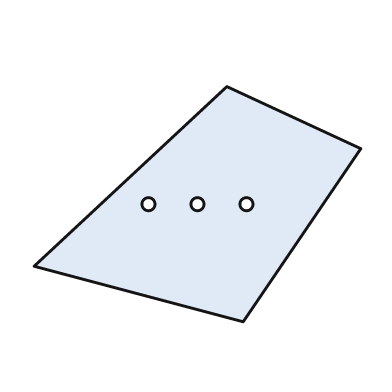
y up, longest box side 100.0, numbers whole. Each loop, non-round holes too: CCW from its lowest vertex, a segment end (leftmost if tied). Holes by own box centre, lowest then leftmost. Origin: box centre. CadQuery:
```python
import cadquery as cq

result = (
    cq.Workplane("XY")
    .moveTo(14.0, -36.0)
    .lineTo(50.0, 17.0)
    .lineTo(9.0, 36.0)
    .lineTo(-50.0, -19.0)
    .close()
    .moveTo(-15.0, 0.0)
    .circle(2.0)
    .moveTo(0.0, 0.0)
    .circle(2.0)
    .moveTo(15.0, 0.0)
    .circle(2.0)
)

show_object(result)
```